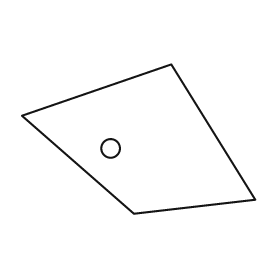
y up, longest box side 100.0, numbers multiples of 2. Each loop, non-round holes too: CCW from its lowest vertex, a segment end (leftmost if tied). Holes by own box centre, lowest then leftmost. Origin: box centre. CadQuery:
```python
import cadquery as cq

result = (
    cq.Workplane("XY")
    .moveTo(-2.0, -32.0)
    .lineTo(50.0, -26.0)
    .lineTo(14.0, 32.0)
    .lineTo(-50.0, 10.0)
    .close()
    .moveTo(-12.0, -4.0)
    .circle(4.0)
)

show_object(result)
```